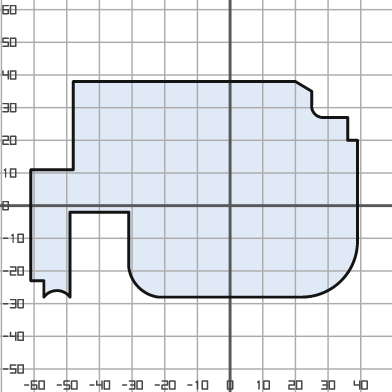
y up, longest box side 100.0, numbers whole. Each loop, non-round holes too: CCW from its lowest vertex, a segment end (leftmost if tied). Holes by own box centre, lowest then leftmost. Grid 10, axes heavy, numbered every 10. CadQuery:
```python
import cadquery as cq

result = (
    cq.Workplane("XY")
    .moveTo(-57.0, -28.0)
    .threePointArc((-53.0, -26.0), (-49.0, -28.0))
    .lineTo(-49.0, -2.0)
    .lineTo(-31.0, -2.0)
    .lineTo(-31.0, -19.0)
    .threePointArc((-28.0, -25.0), (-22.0, -28.0))
    .lineTo(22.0, -28.0)
    .threePointArc((34.0, -23.0), (39.0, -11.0))
    .lineTo(39.0, 20.0)
    .lineTo(36.0, 20.0)
    .lineTo(36.0, 27.0)
    .lineTo(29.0, 27.0)
    .threePointArc((26.0, 28.0), (25.0, 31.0))
    .lineTo(25.0, 35.0)
    .lineTo(20.0, 38.0)
    .lineTo(-48.0, 38.0)
    .lineTo(-48.0, 11.0)
    .lineTo(-61.0, 11.0)
    .lineTo(-61.0, -23.0)
    .lineTo(-57.0, -23.0)
    .close()
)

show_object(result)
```